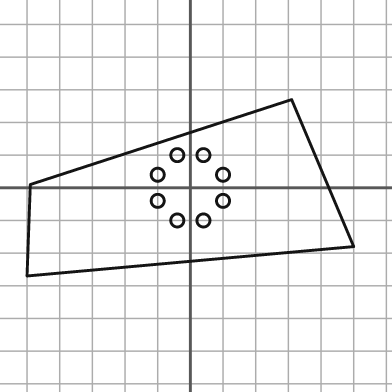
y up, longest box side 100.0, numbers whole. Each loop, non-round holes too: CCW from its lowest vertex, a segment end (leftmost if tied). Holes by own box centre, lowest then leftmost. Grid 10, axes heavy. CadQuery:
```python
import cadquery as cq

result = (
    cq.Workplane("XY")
    .moveTo(-50.0, -27.0)
    .lineTo(50.0, -18.0)
    .lineTo(31.0, 27.0)
    .lineTo(-49.0, 1.0)
    .close()
    .moveTo(-4.0, -10.0)
    .circle(2.0)
    .moveTo(4.0, -10.0)
    .circle(2.0)
    .moveTo(-10.0, -4.0)
    .circle(2.0)
    .moveTo(10.0, -4.0)
    .circle(2.0)
    .moveTo(-10.0, 4.0)
    .circle(2.0)
    .moveTo(10.0, 4.0)
    .circle(2.0)
    .moveTo(-4.0, 10.0)
    .circle(2.0)
    .moveTo(4.0, 10.0)
    .circle(2.0)
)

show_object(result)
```